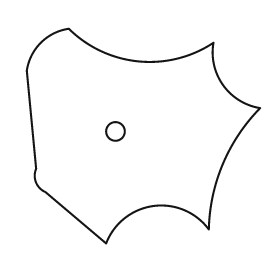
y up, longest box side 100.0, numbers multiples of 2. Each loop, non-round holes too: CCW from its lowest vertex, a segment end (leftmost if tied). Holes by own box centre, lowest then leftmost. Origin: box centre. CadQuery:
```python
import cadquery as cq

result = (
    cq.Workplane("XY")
    .moveTo(-16.0, -46.0)
    .threePointArc((4.0, -30.0), (28.0, -40.0))
    .threePointArc((34.0, -12.0), (50.0, 12.0))
    .threePointArc((34.0, 22.0), (30.0, 40.0))
    .threePointArc((-2.0, 32.0), (-32.0, 46.0))
    .threePointArc((-44.0, 40.0), (-50.0, 28.0))
    .lineTo(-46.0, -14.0)
    .threePointArc((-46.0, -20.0), (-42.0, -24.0))
    .close()
    .moveTo(-12.0, 2.0)
    .circle(4.0)
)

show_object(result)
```